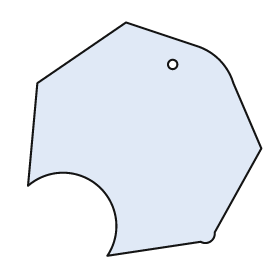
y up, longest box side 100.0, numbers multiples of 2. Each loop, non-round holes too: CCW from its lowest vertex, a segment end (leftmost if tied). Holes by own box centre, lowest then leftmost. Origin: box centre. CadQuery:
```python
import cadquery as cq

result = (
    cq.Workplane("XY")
    .moveTo(-16.0, -50.0)
    .lineTo(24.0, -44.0)
    .threePointArc((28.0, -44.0), (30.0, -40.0))
    .lineTo(50.0, -4.0)
    .lineTo(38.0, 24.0)
    .threePointArc((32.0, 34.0), (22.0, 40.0))
    .lineTo(-8.0, 50.0)
    .lineTo(-46.0, 24.0)
    .lineTo(-50.0, -20.0)
    .threePointArc((-20.0, -20.0), (-16.0, -50.0))
    .close()
    .moveTo(12.0, 32.0)
    .circle(2.0)
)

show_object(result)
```